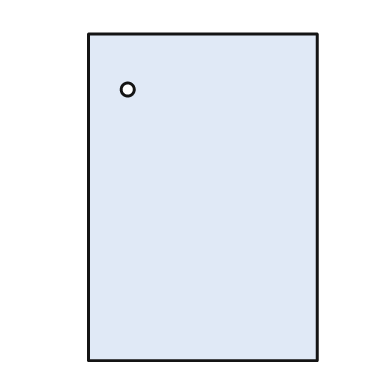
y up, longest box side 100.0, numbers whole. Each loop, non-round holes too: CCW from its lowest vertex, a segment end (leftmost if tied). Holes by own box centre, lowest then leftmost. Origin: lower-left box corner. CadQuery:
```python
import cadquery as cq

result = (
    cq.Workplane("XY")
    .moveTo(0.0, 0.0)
    .lineTo(70.0, 0.0)
    .lineTo(70.0, 100.0)
    .lineTo(0.0, 100.0)
    .close()
    .moveTo(12.0, 83.0)
    .circle(2.0)
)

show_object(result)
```